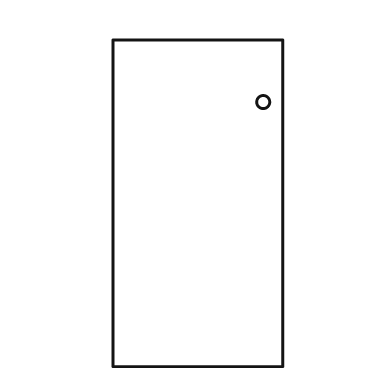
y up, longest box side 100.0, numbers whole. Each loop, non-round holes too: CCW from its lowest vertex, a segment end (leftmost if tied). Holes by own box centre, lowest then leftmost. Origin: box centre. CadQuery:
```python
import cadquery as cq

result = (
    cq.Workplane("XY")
    .moveTo(-26.0, -50.0)
    .lineTo(26.0, -50.0)
    .lineTo(26.0, 50.0)
    .lineTo(-26.0, 50.0)
    .close()
    .moveTo(20.0, 31.0)
    .circle(2.0)
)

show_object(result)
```